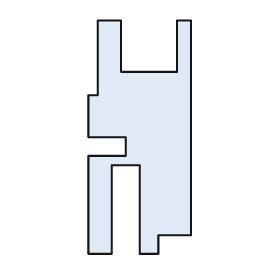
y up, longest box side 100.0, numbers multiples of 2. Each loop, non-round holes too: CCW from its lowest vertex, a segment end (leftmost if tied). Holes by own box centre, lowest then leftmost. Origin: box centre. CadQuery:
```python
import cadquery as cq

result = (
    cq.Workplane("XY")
    .moveTo(-22.0, -50.0)
    .lineTo(-12.0, -50.0)
    .lineTo(-12.0, -12.0)
    .lineTo(0.0, -12.0)
    .lineTo(0.0, -50.0)
    .lineTo(8.0, -50.0)
    .lineTo(8.0, -42.0)
    .lineTo(22.0, -42.0)
    .lineTo(22.0, 50.0)
    .lineTo(16.0, 50.0)
    .lineTo(16.0, 28.0)
    .lineTo(-8.0, 28.0)
    .lineTo(-8.0, 50.0)
    .lineTo(-18.0, 50.0)
    .lineTo(-18.0, 18.0)
    .lineTo(-22.0, 18.0)
    .lineTo(-22.0, 0.0)
    .lineTo(-6.0, 0.0)
    .lineTo(-6.0, -8.0)
    .lineTo(-22.0, -8.0)
    .close()
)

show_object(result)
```